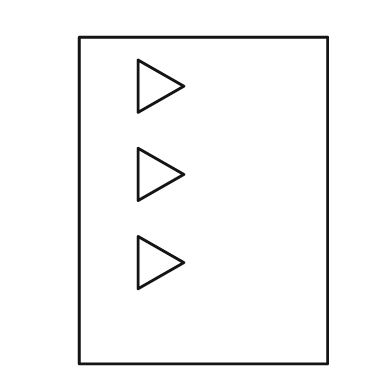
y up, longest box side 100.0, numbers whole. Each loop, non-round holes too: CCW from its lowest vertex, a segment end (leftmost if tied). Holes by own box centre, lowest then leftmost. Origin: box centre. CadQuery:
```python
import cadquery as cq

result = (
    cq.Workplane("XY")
    .moveTo(-38.0, -50.0)
    .lineTo(38.0, -50.0)
    .lineTo(38.0, 50.0)
    .lineTo(-38.0, 50.0)
    .close()
    .moveTo(-20.0, -27.0)
    .lineTo(-6.0, -19.0)
    .lineTo(-20.0, -11.0)
    .close()
    .moveTo(-20.0, 0.0)
    .lineTo(-6.0, 8.0)
    .lineTo(-20.0, 16.0)
    .close()
    .moveTo(-20.0, 27.0)
    .lineTo(-6.0, 35.0)
    .lineTo(-20.0, 43.0)
    .close()
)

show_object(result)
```